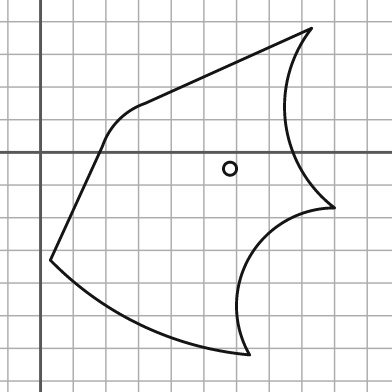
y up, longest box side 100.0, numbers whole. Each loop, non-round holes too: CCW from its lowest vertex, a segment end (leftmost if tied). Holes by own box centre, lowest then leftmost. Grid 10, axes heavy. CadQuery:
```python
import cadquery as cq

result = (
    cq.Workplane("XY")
    .moveTo(64.0, -62.0)
    .threePointArc((64.0, -32.0), (90.0, -17.0))
    .threePointArc((75.0, 9.0), (83.0, 38.0))
    .lineTo(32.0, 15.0)
    .threePointArc((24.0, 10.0), (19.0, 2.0))
    .lineTo(3.0, -33.0)
    .threePointArc((31.0, -53.0), (64.0, -62.0))
    .close()
    .moveTo(58.0, -5.0)
    .circle(2.0)
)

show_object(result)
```